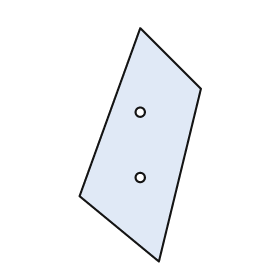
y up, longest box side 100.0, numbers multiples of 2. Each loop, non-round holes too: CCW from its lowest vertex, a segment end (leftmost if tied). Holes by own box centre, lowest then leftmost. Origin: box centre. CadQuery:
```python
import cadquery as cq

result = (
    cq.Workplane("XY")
    .moveTo(8.0, -50.0)
    .lineTo(26.0, 24.0)
    .lineTo(0.0, 50.0)
    .lineTo(-26.0, -22.0)
    .close()
    .moveTo(0.0, -14.0)
    .circle(2.0)
    .moveTo(0.0, 14.0)
    .circle(2.0)
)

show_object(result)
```